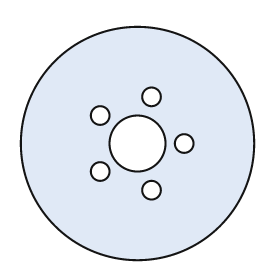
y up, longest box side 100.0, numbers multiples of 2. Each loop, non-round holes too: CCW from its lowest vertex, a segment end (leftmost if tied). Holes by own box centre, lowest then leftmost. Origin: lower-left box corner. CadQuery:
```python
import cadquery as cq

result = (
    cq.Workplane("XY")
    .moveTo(50.0, 50.0)
    .circle(50.0)
    .moveTo(56.0, 30.0)
    .circle(4.0)
    .moveTo(34.0, 38.0)
    .circle(4.0)
    .moveTo(50.0, 50.0)
    .circle(12.0)
    .moveTo(70.0, 50.0)
    .circle(4.0)
    .moveTo(34.0, 62.0)
    .circle(4.0)
    .moveTo(56.0, 70.0)
    .circle(4.0)
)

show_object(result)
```